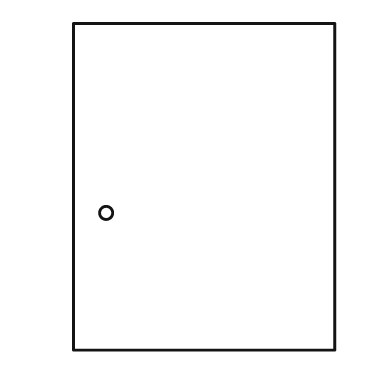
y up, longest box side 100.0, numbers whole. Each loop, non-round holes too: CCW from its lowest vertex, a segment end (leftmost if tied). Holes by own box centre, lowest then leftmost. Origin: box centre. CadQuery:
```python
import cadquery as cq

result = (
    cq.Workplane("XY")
    .moveTo(-40.0, -50.0)
    .lineTo(40.0, -50.0)
    .lineTo(40.0, 50.0)
    .lineTo(-40.0, 50.0)
    .close()
    .moveTo(-30.0, -8.0)
    .circle(2.0)
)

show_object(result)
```